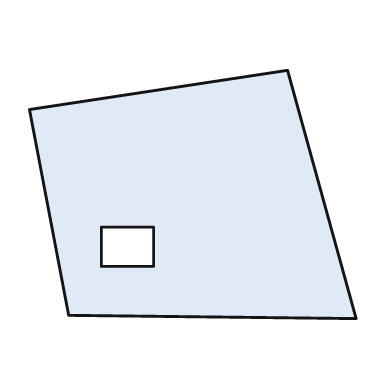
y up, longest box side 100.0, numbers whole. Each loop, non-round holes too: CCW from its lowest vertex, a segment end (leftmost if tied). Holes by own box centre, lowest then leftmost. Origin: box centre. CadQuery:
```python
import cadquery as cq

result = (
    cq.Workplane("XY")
    .moveTo(50.0, -38.0)
    .lineTo(29.0, 38.0)
    .lineTo(-50.0, 26.0)
    .lineTo(-38.0, -37.0)
    .close()
    .moveTo(-28.0, -22.0)
    .lineTo(-12.0, -22.0)
    .lineTo(-12.0, -10.0)
    .lineTo(-28.0, -10.0)
    .close()
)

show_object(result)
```